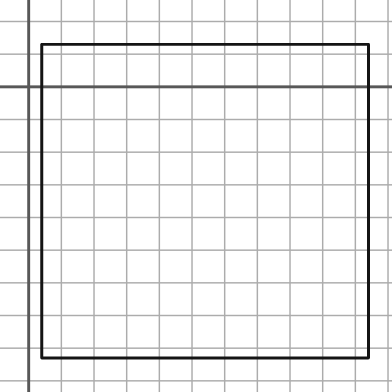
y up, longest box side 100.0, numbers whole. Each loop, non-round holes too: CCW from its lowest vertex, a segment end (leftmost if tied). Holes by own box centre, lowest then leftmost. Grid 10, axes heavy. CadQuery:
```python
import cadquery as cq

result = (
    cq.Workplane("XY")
    .moveTo(4.0, -83.0)
    .lineTo(104.0, -83.0)
    .lineTo(104.0, 13.0)
    .lineTo(4.0, 13.0)
    .close()
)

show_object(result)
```